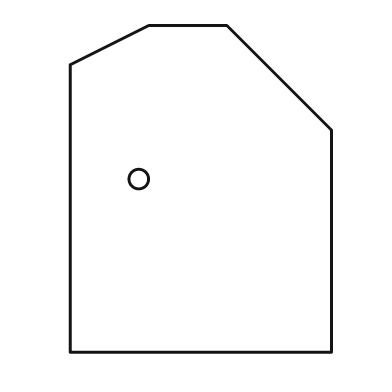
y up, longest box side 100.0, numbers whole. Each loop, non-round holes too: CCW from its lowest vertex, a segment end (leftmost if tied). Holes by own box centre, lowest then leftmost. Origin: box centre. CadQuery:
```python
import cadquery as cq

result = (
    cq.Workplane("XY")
    .moveTo(-40.0, -50.0)
    .lineTo(40.0, -50.0)
    .lineTo(40.0, 18.0)
    .lineTo(8.0, 50.0)
    .lineTo(-16.0, 50.0)
    .lineTo(-40.0, 38.0)
    .close()
    .moveTo(-19.0, 3.0)
    .circle(3.0)
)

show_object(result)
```